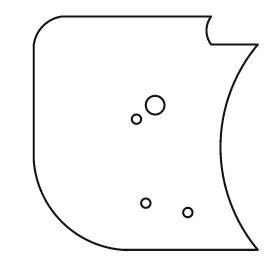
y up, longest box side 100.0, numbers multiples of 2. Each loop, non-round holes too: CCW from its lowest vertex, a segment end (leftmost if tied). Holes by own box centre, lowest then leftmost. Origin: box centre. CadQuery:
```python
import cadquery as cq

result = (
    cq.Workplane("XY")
    .moveTo(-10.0, -50.0)
    .lineTo(48.0, -50.0)
    .threePointArc((32.0, -6.0), (48.0, 38.0))
    .lineTo(28.0, 38.0)
    .threePointArc((26.0, 44.0), (28.0, 50.0))
    .lineTo(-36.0, 50.0)
    .threePointArc((-44.0, 46.0), (-48.0, 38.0))
    .lineTo(-48.0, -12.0)
    .threePointArc((-36.0, -38.0), (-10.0, -50.0))
    .close()
    .moveTo(18.0, -34.0)
    .circle(2.0)
    .moveTo(0.0, -30.0)
    .circle(2.0)
    .moveTo(-4.0, 6.0)
    .circle(2.0)
    .moveTo(4.0, 12.0)
    .circle(4.0)
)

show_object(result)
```